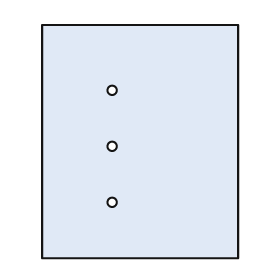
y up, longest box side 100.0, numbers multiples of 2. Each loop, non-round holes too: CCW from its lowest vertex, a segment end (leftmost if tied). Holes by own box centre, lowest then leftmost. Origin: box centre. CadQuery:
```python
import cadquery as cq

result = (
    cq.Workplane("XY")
    .moveTo(-42.0, -50.0)
    .lineTo(42.0, -50.0)
    .lineTo(42.0, 50.0)
    .lineTo(-42.0, 50.0)
    .close()
    .moveTo(-12.0, -26.0)
    .circle(2.0)
    .moveTo(-12.0, -2.0)
    .circle(2.0)
    .moveTo(-12.0, 22.0)
    .circle(2.0)
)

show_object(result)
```